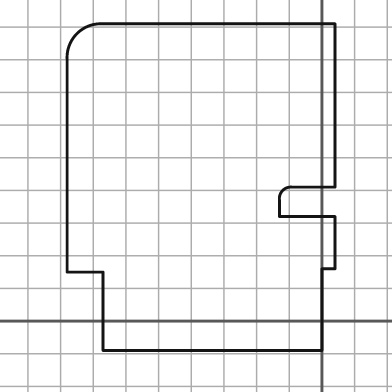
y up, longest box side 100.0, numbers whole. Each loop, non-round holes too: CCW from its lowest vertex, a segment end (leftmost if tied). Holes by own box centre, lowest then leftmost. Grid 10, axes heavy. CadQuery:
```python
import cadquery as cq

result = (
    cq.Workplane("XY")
    .moveTo(-67.0, -9.0)
    .lineTo(0.0, -9.0)
    .lineTo(0.0, 16.0)
    .lineTo(4.0, 16.0)
    .lineTo(4.0, 32.0)
    .lineTo(-13.0, 32.0)
    .lineTo(-13.0, 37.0)
    .threePointArc((-12.0, 40.0), (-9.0, 41.0))
    .lineTo(4.0, 41.0)
    .lineTo(4.0, 91.0)
    .lineTo(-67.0, 91.0)
    .threePointArc((-75.0, 88.0), (-78.0, 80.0))
    .lineTo(-78.0, 15.0)
    .lineTo(-67.0, 15.0)
    .close()
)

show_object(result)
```